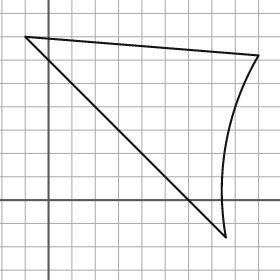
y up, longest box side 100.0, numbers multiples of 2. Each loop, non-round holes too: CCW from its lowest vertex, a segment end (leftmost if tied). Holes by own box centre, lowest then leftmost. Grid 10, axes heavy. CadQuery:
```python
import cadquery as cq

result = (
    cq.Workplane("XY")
    .moveTo(76.0, -16.0)
    .threePointArc((76.0, 24.0), (90.0, 62.0))
    .lineTo(-10.0, 70.0)
    .close()
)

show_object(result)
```